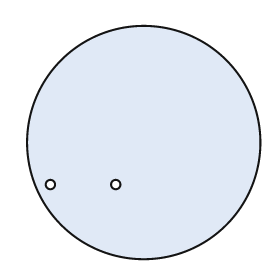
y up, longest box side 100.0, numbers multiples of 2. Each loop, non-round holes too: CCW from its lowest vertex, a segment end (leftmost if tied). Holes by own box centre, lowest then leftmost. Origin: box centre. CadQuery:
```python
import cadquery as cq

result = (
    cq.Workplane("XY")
    .moveTo(0.0, 0.0)
    .circle(50.0)
    .moveTo(-40.0, -18.0)
    .circle(2.0)
    .moveTo(-12.0, -18.0)
    .circle(2.0)
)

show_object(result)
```